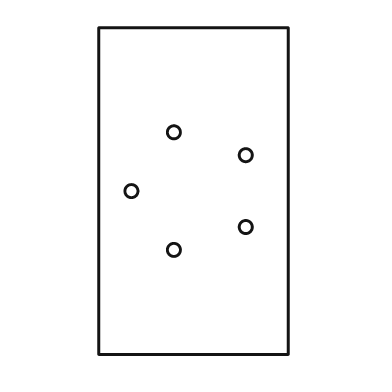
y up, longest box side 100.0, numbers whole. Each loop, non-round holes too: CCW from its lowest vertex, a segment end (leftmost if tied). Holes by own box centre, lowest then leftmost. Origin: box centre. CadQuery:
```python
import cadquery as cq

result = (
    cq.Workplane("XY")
    .moveTo(-29.0, -50.0)
    .lineTo(29.0, -50.0)
    .lineTo(29.0, 50.0)
    .lineTo(-29.0, 50.0)
    .close()
    .moveTo(-6.0, -18.0)
    .circle(2.0)
    .moveTo(16.0, -11.0)
    .circle(2.0)
    .moveTo(-19.0, 0.0)
    .circle(2.0)
    .moveTo(16.0, 11.0)
    .circle(2.0)
    .moveTo(-6.0, 18.0)
    .circle(2.0)
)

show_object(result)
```